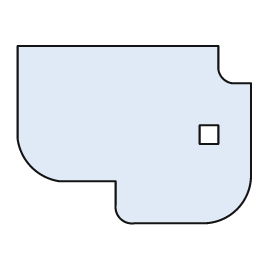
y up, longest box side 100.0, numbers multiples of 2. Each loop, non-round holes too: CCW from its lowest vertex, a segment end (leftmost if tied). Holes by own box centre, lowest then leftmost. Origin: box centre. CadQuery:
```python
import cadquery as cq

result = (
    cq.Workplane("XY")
    .moveTo(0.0, -38.0)
    .lineTo(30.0, -38.0)
    .threePointArc((44.0, -32.0), (50.0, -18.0))
    .lineTo(50.0, 22.0)
    .lineTo(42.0, 22.0)
    .threePointArc((38.0, 24.0), (36.0, 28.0))
    .lineTo(36.0, 38.0)
    .lineTo(-50.0, 38.0)
    .lineTo(-50.0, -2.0)
    .threePointArc((-44.0, -14.0), (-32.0, -20.0))
    .lineTo(-8.0, -20.0)
    .lineTo(-8.0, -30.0)
    .threePointArc((-6.0, -36.0), (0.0, -38.0))
    .close()
    .moveTo(28.0, -4.0)
    .lineTo(36.0, -4.0)
    .lineTo(36.0, 4.0)
    .lineTo(28.0, 4.0)
    .close()
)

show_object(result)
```